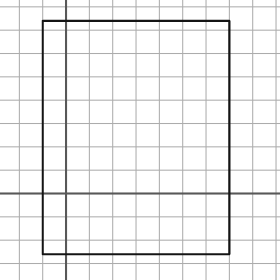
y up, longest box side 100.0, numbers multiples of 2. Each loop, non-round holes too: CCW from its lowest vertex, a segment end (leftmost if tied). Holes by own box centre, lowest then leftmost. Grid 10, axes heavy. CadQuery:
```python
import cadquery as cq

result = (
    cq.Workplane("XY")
    .moveTo(-10.0, -26.0)
    .lineTo(70.0, -26.0)
    .lineTo(70.0, 74.0)
    .lineTo(-10.0, 74.0)
    .close()
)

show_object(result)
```